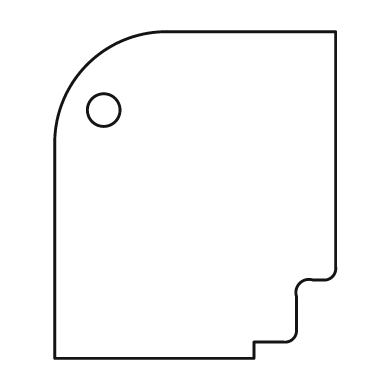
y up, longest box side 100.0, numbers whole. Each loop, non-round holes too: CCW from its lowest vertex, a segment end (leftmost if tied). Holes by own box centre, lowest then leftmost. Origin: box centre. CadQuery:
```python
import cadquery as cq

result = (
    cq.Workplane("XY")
    .moveTo(-43.0, -50.0)
    .lineTo(18.0, -50.0)
    .lineTo(18.0, -45.0)
    .lineTo(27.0, -45.0)
    .threePointArc((30.0, -44.0), (31.0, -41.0))
    .lineTo(31.0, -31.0)
    .threePointArc((32.0, -27.0), (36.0, -26.0))
    .lineTo(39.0, -26.0)
    .threePointArc((42.0, -25.0), (43.0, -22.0))
    .lineTo(43.0, 50.0)
    .lineTo(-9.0, 50.0)
    .threePointArc((-33.0, 40.0), (-43.0, 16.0))
    .close()
    .moveTo(-28.0, 26.0)
    .circle(5.0)
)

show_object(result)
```